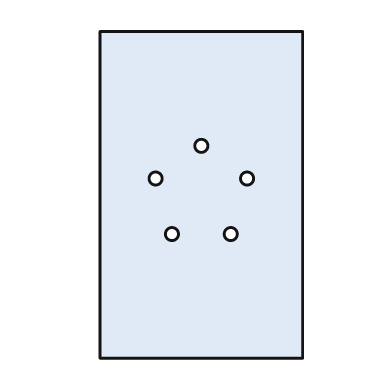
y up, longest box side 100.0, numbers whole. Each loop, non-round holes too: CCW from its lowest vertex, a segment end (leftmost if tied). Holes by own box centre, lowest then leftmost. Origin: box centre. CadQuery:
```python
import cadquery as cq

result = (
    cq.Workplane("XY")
    .moveTo(-31.0, -50.0)
    .lineTo(31.0, -50.0)
    .lineTo(31.0, 50.0)
    .lineTo(-31.0, 50.0)
    .close()
    .moveTo(-9.0, -12.0)
    .circle(2.0)
    .moveTo(9.0, -12.0)
    .circle(2.0)
    .moveTo(-14.0, 5.0)
    .circle(2.0)
    .moveTo(14.0, 5.0)
    .circle(2.0)
    .moveTo(0.0, 15.0)
    .circle(2.0)
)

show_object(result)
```